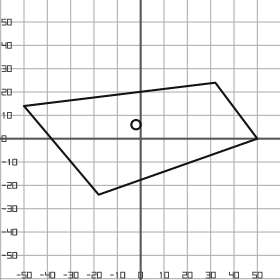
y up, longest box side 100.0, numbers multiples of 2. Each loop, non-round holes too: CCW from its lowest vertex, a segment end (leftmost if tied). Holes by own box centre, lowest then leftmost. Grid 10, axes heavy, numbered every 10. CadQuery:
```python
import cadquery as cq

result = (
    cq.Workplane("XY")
    .moveTo(-18.0, -24.0)
    .lineTo(50.0, 0.0)
    .lineTo(32.0, 24.0)
    .lineTo(-50.0, 14.0)
    .close()
    .moveTo(-2.0, 6.0)
    .circle(2.0)
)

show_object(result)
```